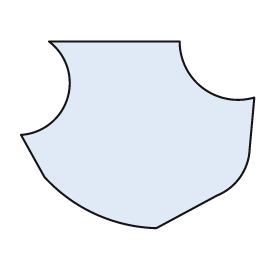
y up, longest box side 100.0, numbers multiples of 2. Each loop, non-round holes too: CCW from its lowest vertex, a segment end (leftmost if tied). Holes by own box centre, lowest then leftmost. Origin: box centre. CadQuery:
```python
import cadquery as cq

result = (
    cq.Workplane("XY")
    .moveTo(8.0, -40.0)
    .lineTo(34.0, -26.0)
    .threePointArc((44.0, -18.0), (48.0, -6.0))
    .lineTo(50.0, 16.0)
    .threePointArc((28.0, 20.0), (18.0, 40.0))
    .lineTo(-38.0, 40.0)
    .threePointArc((-30.0, 16.0), (-50.0, 0.0))
    .lineTo(-40.0, -18.0)
    .threePointArc((-18.0, -34.0), (8.0, -40.0))
    .close()
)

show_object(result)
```